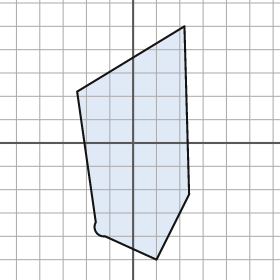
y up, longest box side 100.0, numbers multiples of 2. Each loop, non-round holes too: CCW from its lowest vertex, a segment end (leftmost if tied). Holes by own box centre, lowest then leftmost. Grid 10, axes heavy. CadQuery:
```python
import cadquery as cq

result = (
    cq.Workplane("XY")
    .moveTo(10.0, -50.0)
    .lineTo(24.0, -22.0)
    .lineTo(22.0, 50.0)
    .lineTo(-24.0, 22.0)
    .lineTo(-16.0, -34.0)
    .threePointArc((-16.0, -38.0), (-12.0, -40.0))
    .close()
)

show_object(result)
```